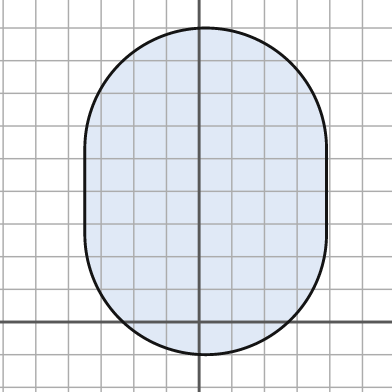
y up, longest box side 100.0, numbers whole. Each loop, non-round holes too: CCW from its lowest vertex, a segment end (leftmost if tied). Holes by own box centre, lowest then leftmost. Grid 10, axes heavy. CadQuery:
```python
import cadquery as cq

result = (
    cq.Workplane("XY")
    .moveTo(-35.0, 27.0)
    .threePointArc((2.0, -10.0), (39.0, 27.0))
    .lineTo(39.0, 53.0)
    .threePointArc((2.0, 90.0), (-35.0, 53.0))
    .close()
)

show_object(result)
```